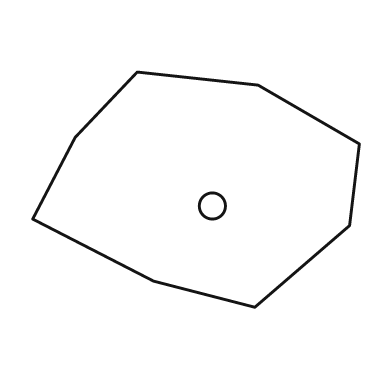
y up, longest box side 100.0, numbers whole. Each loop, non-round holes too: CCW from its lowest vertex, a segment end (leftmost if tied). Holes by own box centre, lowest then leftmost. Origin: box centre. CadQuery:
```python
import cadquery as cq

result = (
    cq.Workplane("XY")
    .moveTo(18.0, -36.0)
    .lineTo(47.0, -11.0)
    .lineTo(50.0, 14.0)
    .lineTo(19.0, 32.0)
    .lineTo(-18.0, 36.0)
    .lineTo(-37.0, 16.0)
    .lineTo(-50.0, -9.0)
    .lineTo(-13.0, -28.0)
    .close()
    .moveTo(5.0, -5.0)
    .circle(4.0)
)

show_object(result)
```